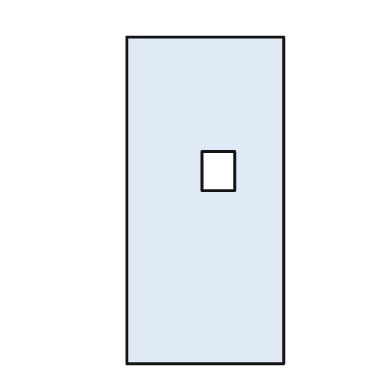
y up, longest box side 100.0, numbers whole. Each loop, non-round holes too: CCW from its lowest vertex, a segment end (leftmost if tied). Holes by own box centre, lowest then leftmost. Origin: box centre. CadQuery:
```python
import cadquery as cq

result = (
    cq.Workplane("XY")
    .moveTo(-24.0, -50.0)
    .lineTo(24.0, -50.0)
    .lineTo(24.0, 50.0)
    .lineTo(-24.0, 50.0)
    .close()
    .moveTo(-1.0, 3.0)
    .lineTo(9.0, 3.0)
    .lineTo(9.0, 15.0)
    .lineTo(-1.0, 15.0)
    .close()
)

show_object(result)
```